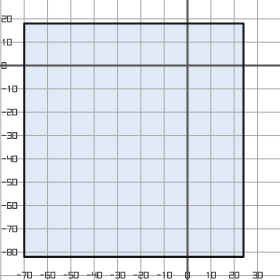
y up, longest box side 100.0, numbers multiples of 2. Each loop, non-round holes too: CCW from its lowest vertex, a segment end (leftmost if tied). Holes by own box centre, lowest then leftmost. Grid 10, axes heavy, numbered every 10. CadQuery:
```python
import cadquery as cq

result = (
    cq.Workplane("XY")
    .moveTo(-70.0, -82.0)
    .lineTo(24.0, -82.0)
    .lineTo(24.0, 18.0)
    .lineTo(-70.0, 18.0)
    .close()
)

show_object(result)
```